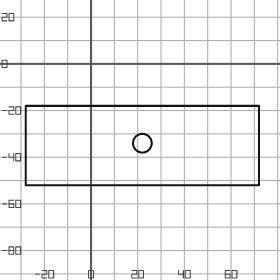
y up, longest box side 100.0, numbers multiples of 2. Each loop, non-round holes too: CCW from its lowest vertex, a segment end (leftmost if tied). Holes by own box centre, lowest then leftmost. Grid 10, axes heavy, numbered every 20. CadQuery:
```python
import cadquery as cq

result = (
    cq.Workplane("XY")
    .moveTo(-28.0, -52.0)
    .lineTo(72.0, -52.0)
    .lineTo(72.0, -18.0)
    .lineTo(-28.0, -18.0)
    .close()
    .moveTo(22.0, -34.0)
    .circle(4.0)
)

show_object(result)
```